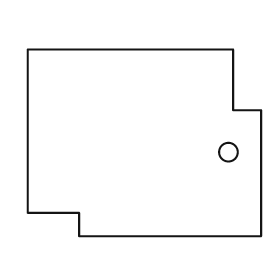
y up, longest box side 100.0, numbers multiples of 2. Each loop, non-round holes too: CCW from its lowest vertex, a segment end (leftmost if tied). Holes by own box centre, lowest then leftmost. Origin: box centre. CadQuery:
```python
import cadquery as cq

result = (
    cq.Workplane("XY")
    .moveTo(-28.0, -40.0)
    .lineTo(50.0, -40.0)
    .lineTo(50.0, 14.0)
    .lineTo(38.0, 14.0)
    .lineTo(38.0, 40.0)
    .lineTo(-50.0, 40.0)
    .lineTo(-50.0, -30.0)
    .lineTo(-28.0, -30.0)
    .close()
    .moveTo(36.0, -4.0)
    .circle(4.0)
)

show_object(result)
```